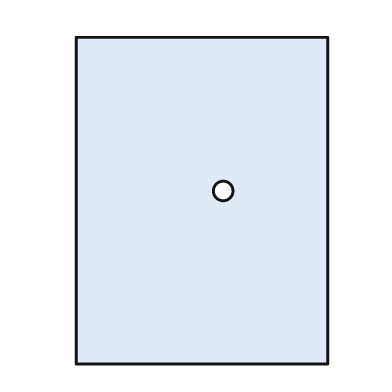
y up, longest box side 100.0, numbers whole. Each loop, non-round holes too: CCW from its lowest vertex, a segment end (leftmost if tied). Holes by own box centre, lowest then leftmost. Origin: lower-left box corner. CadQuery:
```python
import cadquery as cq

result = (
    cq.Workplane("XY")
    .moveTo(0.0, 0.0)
    .lineTo(77.0, 0.0)
    .lineTo(77.0, 100.0)
    .lineTo(0.0, 100.0)
    .close()
    .moveTo(45.0, 53.0)
    .circle(3.0)
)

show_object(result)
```